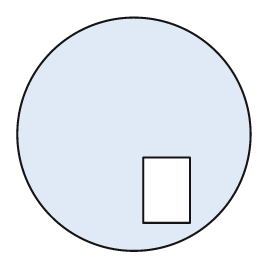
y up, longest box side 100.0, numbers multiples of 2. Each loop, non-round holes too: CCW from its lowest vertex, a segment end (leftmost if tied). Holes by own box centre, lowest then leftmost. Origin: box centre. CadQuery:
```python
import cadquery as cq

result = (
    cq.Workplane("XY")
    .moveTo(0.0, 0.0)
    .circle(50.0)
    .moveTo(4.0, -38.0)
    .lineTo(24.0, -38.0)
    .lineTo(24.0, -10.0)
    .lineTo(4.0, -10.0)
    .close()
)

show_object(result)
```